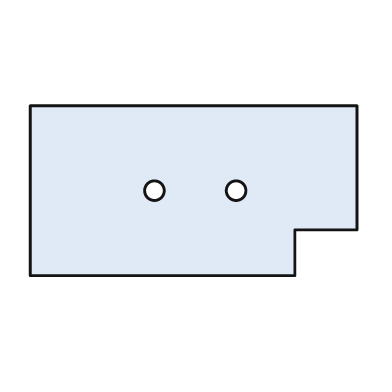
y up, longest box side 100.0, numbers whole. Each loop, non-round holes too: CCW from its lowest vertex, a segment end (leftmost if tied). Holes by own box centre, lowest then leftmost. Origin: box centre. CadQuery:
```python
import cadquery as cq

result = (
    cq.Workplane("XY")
    .moveTo(-50.0, -26.0)
    .lineTo(31.0, -26.0)
    .lineTo(31.0, -12.0)
    .lineTo(50.0, -12.0)
    .lineTo(50.0, 26.0)
    .lineTo(-50.0, 26.0)
    .close()
    .moveTo(-12.0, 0.0)
    .circle(3.0)
    .moveTo(13.0, 0.0)
    .circle(3.0)
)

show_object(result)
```